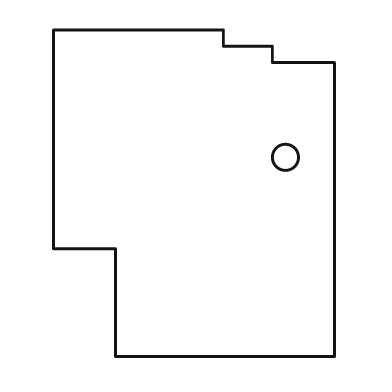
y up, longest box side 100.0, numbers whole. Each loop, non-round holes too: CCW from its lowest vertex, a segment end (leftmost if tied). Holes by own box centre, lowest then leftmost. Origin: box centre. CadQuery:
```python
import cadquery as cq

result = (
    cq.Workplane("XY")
    .moveTo(-24.0, -50.0)
    .lineTo(43.0, -50.0)
    .lineTo(43.0, 40.0)
    .lineTo(24.0, 40.0)
    .lineTo(24.0, 45.0)
    .lineTo(9.0, 45.0)
    .lineTo(9.0, 50.0)
    .lineTo(-43.0, 50.0)
    .lineTo(-43.0, -17.0)
    .lineTo(-24.0, -17.0)
    .close()
    .moveTo(28.0, 11.0)
    .circle(4.0)
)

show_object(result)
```